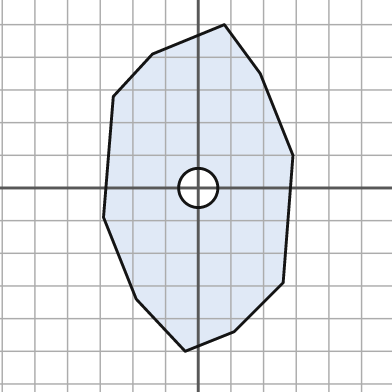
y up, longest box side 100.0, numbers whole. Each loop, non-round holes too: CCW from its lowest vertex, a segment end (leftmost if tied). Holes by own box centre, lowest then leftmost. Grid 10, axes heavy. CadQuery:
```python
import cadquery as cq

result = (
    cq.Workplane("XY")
    .moveTo(-4.0, -50.0)
    .lineTo(11.0, -44.0)
    .lineTo(26.0, -29.0)
    .lineTo(29.0, 10.0)
    .lineTo(19.0, 35.0)
    .lineTo(8.0, 50.0)
    .lineTo(-14.0, 41.0)
    .lineTo(-26.0, 28.0)
    .lineTo(-29.0, -9.0)
    .lineTo(-19.0, -34.0)
    .close()
    .moveTo(0.0, 0.0)
    .circle(6.0)
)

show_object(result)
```